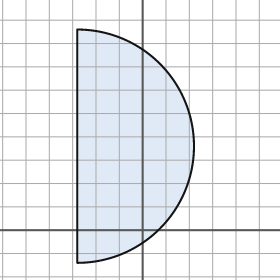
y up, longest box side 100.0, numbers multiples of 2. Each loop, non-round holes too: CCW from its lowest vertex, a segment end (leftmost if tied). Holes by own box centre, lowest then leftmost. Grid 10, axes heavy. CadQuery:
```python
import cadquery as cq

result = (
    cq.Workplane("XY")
    .moveTo(-28.0, -14.0)
    .threePointArc((22.0, 36.0), (-28.0, 86.0))
    .close()
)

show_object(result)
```